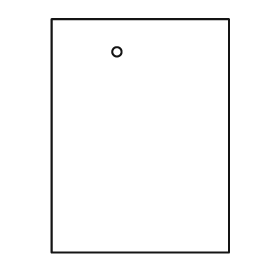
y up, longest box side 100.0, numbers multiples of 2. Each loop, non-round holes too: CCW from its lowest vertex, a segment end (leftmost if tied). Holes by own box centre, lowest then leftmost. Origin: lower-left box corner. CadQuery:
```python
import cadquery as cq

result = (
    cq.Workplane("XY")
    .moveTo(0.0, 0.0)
    .lineTo(76.0, 0.0)
    .lineTo(76.0, 100.0)
    .lineTo(0.0, 100.0)
    .close()
    .moveTo(28.0, 86.0)
    .circle(2.0)
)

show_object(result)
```